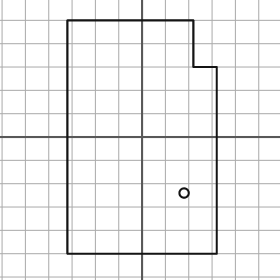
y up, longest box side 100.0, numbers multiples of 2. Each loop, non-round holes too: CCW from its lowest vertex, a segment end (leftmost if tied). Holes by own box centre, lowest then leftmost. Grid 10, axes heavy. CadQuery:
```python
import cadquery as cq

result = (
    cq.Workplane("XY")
    .moveTo(-32.0, -50.0)
    .lineTo(32.0, -50.0)
    .lineTo(32.0, 30.0)
    .lineTo(22.0, 30.0)
    .lineTo(22.0, 50.0)
    .lineTo(-32.0, 50.0)
    .close()
    .moveTo(18.0, -24.0)
    .circle(2.0)
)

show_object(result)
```